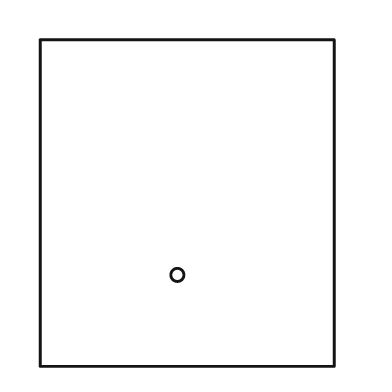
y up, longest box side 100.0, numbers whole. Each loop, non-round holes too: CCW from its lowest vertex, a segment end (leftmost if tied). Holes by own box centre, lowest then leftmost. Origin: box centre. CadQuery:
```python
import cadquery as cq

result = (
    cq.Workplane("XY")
    .moveTo(-45.0, -50.0)
    .lineTo(45.0, -50.0)
    .lineTo(45.0, 50.0)
    .lineTo(-45.0, 50.0)
    .close()
    .moveTo(-3.0, -22.0)
    .circle(2.0)
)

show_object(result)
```